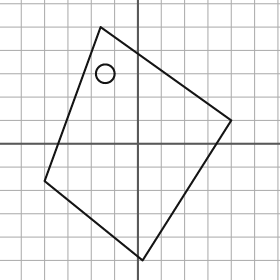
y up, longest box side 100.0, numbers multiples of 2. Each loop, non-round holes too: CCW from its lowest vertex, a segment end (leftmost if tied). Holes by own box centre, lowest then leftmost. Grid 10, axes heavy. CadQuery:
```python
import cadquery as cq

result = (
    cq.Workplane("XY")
    .moveTo(2.0, -50.0)
    .lineTo(40.0, 10.0)
    .lineTo(-16.0, 50.0)
    .lineTo(-40.0, -16.0)
    .close()
    .moveTo(-14.0, 30.0)
    .circle(4.0)
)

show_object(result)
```